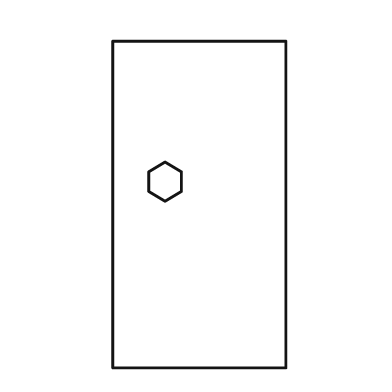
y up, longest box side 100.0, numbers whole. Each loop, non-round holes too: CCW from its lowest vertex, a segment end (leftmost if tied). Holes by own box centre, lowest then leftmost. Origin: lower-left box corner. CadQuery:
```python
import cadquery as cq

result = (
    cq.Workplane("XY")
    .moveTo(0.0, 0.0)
    .lineTo(53.0, 0.0)
    .lineTo(53.0, 100.0)
    .lineTo(0.0, 100.0)
    .close()
    .moveTo(16.0, 51.0)
    .lineTo(21.0, 54.0)
    .lineTo(21.0, 60.0)
    .lineTo(16.0, 63.0)
    .lineTo(11.0, 60.0)
    .lineTo(11.0, 54.0)
    .close()
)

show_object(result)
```